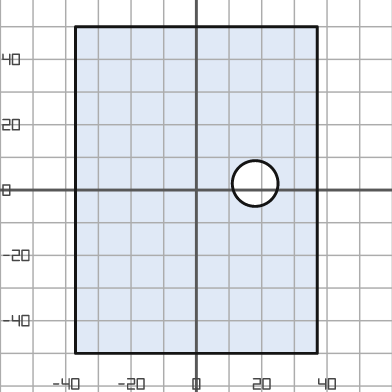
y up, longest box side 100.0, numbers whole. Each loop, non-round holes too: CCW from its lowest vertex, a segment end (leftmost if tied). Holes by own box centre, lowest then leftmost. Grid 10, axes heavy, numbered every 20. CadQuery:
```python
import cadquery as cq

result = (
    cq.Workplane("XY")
    .moveTo(-37.0, -50.0)
    .lineTo(37.0, -50.0)
    .lineTo(37.0, 50.0)
    .lineTo(-37.0, 50.0)
    .close()
    .moveTo(18.0, 2.0)
    .circle(7.0)
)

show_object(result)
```